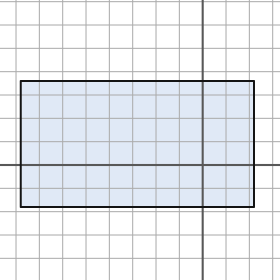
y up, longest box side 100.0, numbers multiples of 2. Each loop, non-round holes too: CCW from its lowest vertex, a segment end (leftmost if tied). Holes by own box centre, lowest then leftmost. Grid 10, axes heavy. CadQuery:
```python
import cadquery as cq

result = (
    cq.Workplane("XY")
    .moveTo(-78.0, -18.0)
    .lineTo(22.0, -18.0)
    .lineTo(22.0, 36.0)
    .lineTo(-78.0, 36.0)
    .close()
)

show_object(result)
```